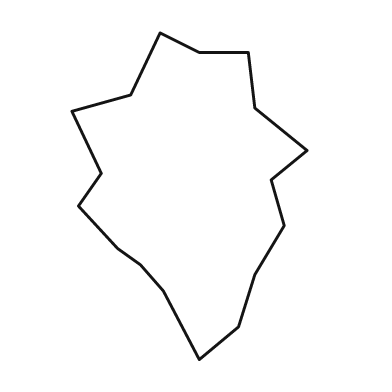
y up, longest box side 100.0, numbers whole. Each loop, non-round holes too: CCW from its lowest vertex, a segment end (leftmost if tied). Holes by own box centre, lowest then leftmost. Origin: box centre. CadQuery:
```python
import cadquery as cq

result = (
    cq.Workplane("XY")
    .moveTo(3.0, -50.0)
    .lineTo(15.0, -40.0)
    .lineTo(20.0, -24.0)
    .lineTo(29.0, -9.0)
    .lineTo(25.0, 5.0)
    .lineTo(36.0, 14.0)
    .lineTo(20.0, 27.0)
    .lineTo(18.0, 44.0)
    .lineTo(3.0, 44.0)
    .lineTo(-9.0, 50.0)
    .lineTo(-18.0, 31.0)
    .lineTo(-36.0, 26.0)
    .lineTo(-27.0, 7.0)
    .lineTo(-34.0, -3.0)
    .lineTo(-22.0, -16.0)
    .lineTo(-15.0, -21.0)
    .lineTo(-8.0, -29.0)
    .close()
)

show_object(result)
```